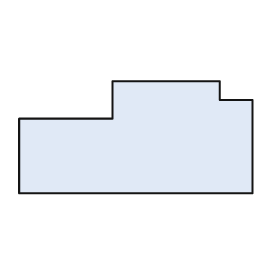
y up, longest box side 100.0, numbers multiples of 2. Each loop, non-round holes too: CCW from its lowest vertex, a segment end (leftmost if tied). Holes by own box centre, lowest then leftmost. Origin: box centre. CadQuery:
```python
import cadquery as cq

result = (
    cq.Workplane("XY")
    .moveTo(-50.0, -24.0)
    .lineTo(50.0, -24.0)
    .lineTo(50.0, 16.0)
    .lineTo(36.0, 16.0)
    .lineTo(36.0, 24.0)
    .lineTo(-10.0, 24.0)
    .lineTo(-10.0, 8.0)
    .lineTo(-50.0, 8.0)
    .close()
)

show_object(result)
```